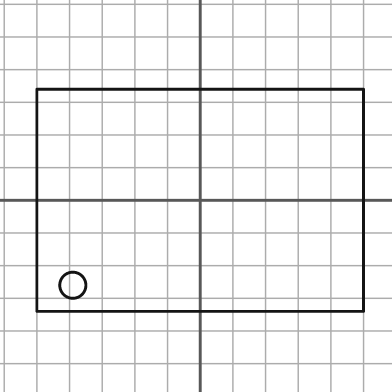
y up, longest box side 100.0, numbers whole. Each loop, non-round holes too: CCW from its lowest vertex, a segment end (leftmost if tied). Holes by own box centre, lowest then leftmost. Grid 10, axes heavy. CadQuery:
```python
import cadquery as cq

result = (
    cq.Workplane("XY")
    .moveTo(-50.0, -34.0)
    .lineTo(50.0, -34.0)
    .lineTo(50.0, 34.0)
    .lineTo(-50.0, 34.0)
    .close()
    .moveTo(-39.0, -26.0)
    .circle(4.0)
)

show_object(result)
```